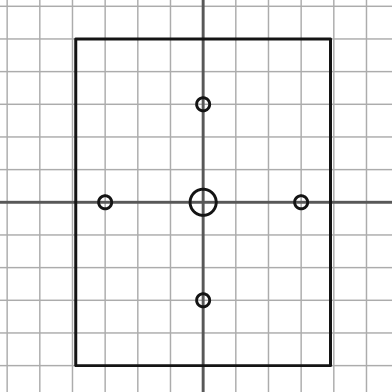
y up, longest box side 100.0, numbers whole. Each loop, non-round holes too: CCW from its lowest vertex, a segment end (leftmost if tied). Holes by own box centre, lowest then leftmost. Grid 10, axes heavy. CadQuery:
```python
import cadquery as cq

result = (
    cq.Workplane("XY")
    .moveTo(-39.0, -50.0)
    .lineTo(39.0, -50.0)
    .lineTo(39.0, 50.0)
    .lineTo(-39.0, 50.0)
    .close()
    .moveTo(0.0, -30.0)
    .circle(2.0)
    .moveTo(-30.0, 0.0)
    .circle(2.0)
    .moveTo(0.0, 0.0)
    .circle(4.0)
    .moveTo(30.0, 0.0)
    .circle(2.0)
    .moveTo(0.0, 30.0)
    .circle(2.0)
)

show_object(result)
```